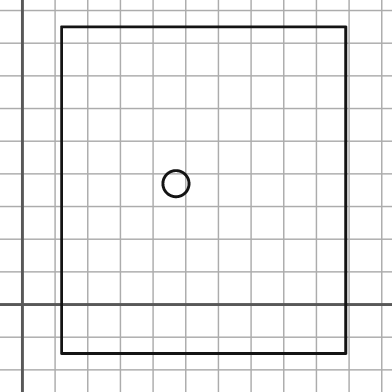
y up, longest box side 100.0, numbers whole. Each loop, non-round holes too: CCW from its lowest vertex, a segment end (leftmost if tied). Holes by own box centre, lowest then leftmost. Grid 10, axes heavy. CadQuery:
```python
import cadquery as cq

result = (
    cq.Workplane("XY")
    .moveTo(12.0, -15.0)
    .lineTo(99.0, -15.0)
    .lineTo(99.0, 85.0)
    .lineTo(12.0, 85.0)
    .close()
    .moveTo(47.0, 37.0)
    .circle(4.0)
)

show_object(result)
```